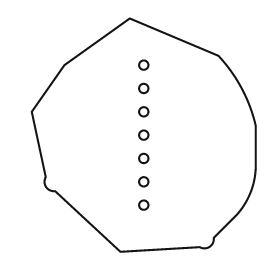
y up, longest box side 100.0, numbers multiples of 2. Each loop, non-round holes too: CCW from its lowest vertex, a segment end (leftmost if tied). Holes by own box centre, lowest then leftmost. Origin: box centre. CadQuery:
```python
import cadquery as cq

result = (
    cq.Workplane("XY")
    .moveTo(-10.0, -50.0)
    .lineTo(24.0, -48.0)
    .threePointArc((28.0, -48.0), (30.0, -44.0))
    .lineTo(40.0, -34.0)
    .threePointArc((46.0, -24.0), (48.0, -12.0))
    .lineTo(48.0, 4.0)
    .threePointArc((42.0, 20.0), (32.0, 34.0))
    .lineTo(-6.0, 50.0)
    .lineTo(-34.0, 30.0)
    .lineTo(-48.0, 10.0)
    .lineTo(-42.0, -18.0)
    .threePointArc((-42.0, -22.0), (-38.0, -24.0))
    .close()
    .moveTo(0.0, -30.0)
    .circle(2.0)
    .moveTo(0.0, -20.0)
    .circle(2.0)
    .moveTo(0.0, -10.0)
    .circle(2.0)
    .moveTo(0.0, 0.0)
    .circle(2.0)
    .moveTo(0.0, 10.0)
    .circle(2.0)
    .moveTo(0.0, 20.0)
    .circle(2.0)
    .moveTo(0.0, 30.0)
    .circle(2.0)
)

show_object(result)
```